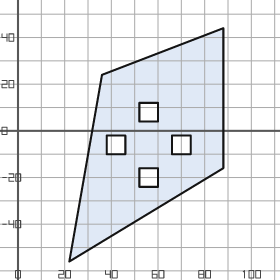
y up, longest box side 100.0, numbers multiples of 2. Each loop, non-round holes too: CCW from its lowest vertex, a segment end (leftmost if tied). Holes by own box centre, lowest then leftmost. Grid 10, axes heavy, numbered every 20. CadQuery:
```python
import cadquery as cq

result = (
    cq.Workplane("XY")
    .moveTo(22.0, -56.0)
    .lineTo(88.0, -16.0)
    .lineTo(88.0, 44.0)
    .lineTo(36.0, 24.0)
    .close()
    .moveTo(52.0, -24.0)
    .lineTo(60.0, -24.0)
    .lineTo(60.0, -16.0)
    .lineTo(52.0, -16.0)
    .close()
    .moveTo(38.0, -10.0)
    .lineTo(46.0, -10.0)
    .lineTo(46.0, -2.0)
    .lineTo(38.0, -2.0)
    .close()
    .moveTo(66.0, -10.0)
    .lineTo(74.0, -10.0)
    .lineTo(74.0, -2.0)
    .lineTo(66.0, -2.0)
    .close()
    .moveTo(52.0, 4.0)
    .lineTo(60.0, 4.0)
    .lineTo(60.0, 12.0)
    .lineTo(52.0, 12.0)
    .close()
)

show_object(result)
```